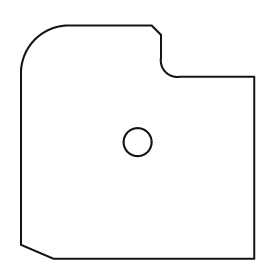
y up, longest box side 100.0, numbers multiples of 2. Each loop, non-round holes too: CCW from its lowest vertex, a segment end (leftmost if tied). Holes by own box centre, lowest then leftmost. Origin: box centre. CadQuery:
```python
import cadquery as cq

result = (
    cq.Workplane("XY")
    .moveTo(-36.0, -50.0)
    .lineTo(50.0, -50.0)
    .lineTo(50.0, 28.0)
    .lineTo(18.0, 28.0)
    .threePointArc((12.0, 30.0), (10.0, 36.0))
    .lineTo(10.0, 46.0)
    .lineTo(6.0, 50.0)
    .lineTo(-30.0, 50.0)
    .threePointArc((-44.0, 44.0), (-50.0, 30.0))
    .lineTo(-50.0, -44.0)
    .close()
    .moveTo(0.0, 0.0)
    .circle(6.0)
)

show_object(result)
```